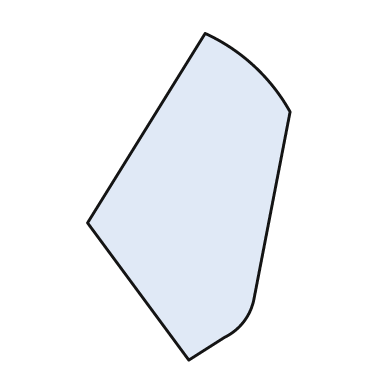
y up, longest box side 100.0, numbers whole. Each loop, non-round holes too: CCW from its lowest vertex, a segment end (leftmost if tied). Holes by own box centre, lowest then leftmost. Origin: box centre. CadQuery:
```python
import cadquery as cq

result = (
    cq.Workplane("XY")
    .moveTo(0.0, -50.0)
    .lineTo(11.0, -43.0)
    .threePointArc((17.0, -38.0), (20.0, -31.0))
    .lineTo(31.0, 26.0)
    .threePointArc((20.0, 40.0), (5.0, 50.0))
    .lineTo(-31.0, -8.0)
    .close()
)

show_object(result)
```